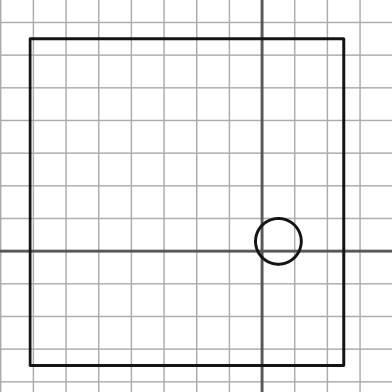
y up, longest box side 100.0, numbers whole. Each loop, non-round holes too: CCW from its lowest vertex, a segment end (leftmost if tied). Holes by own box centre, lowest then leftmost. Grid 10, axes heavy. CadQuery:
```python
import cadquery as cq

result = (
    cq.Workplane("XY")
    .moveTo(-71.0, -35.0)
    .lineTo(25.0, -35.0)
    .lineTo(25.0, 65.0)
    .lineTo(-71.0, 65.0)
    .close()
    .moveTo(5.0, 3.0)
    .circle(7.0)
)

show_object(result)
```